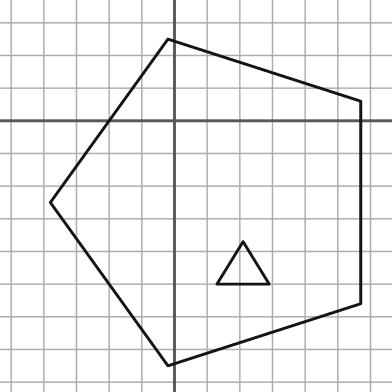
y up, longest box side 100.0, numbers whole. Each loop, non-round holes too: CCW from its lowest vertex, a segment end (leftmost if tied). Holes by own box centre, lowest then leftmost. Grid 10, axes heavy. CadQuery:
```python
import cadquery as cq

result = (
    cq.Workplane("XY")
    .moveTo(-2.0, -75.0)
    .lineTo(57.0, -56.0)
    .lineTo(57.0, 6.0)
    .lineTo(-2.0, 25.0)
    .lineTo(-38.0, -25.0)
    .close()
    .moveTo(13.0, -50.0)
    .lineTo(29.0, -50.0)
    .lineTo(21.0, -37.0)
    .close()
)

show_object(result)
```